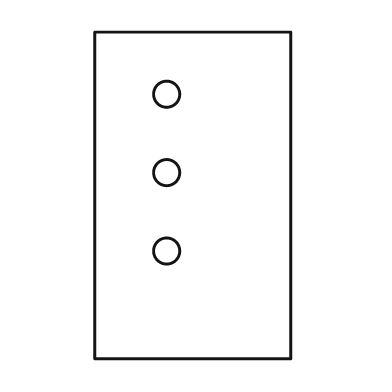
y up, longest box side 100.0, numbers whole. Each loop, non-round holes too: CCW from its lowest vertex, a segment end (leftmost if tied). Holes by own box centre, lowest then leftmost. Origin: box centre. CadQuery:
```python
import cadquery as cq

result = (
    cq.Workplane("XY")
    .moveTo(-30.0, -50.0)
    .lineTo(30.0, -50.0)
    .lineTo(30.0, 50.0)
    .lineTo(-30.0, 50.0)
    .close()
    .moveTo(-8.0, -17.0)
    .circle(4.0)
    .moveTo(-8.0, 7.0)
    .circle(4.0)
    .moveTo(-8.0, 31.0)
    .circle(4.0)
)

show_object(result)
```